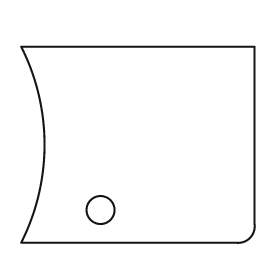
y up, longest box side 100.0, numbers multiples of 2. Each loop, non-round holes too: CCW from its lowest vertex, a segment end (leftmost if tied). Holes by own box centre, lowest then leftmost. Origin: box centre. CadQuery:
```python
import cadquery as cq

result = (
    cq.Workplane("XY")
    .moveTo(-50.0, -42.0)
    .lineTo(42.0, -42.0)
    .threePointArc((48.0, -40.0), (50.0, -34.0))
    .lineTo(50.0, 42.0)
    .lineTo(-50.0, 42.0)
    .threePointArc((-40.0, 0.0), (-50.0, -42.0))
    .close()
    .moveTo(-16.0, -28.0)
    .circle(6.0)
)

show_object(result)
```